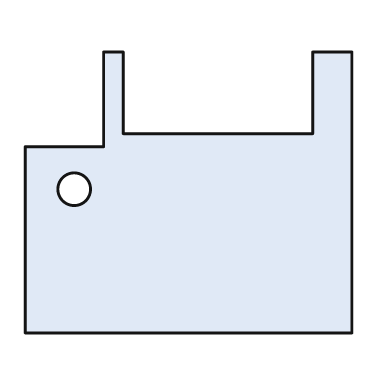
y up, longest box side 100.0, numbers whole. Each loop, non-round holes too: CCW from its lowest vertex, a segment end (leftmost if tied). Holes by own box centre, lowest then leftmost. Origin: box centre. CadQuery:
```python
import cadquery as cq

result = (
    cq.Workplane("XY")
    .moveTo(-50.0, -43.0)
    .lineTo(50.0, -43.0)
    .lineTo(50.0, 43.0)
    .lineTo(38.0, 43.0)
    .lineTo(38.0, 18.0)
    .lineTo(-20.0, 18.0)
    .lineTo(-20.0, 43.0)
    .lineTo(-26.0, 43.0)
    .lineTo(-26.0, 14.0)
    .lineTo(-50.0, 14.0)
    .close()
    .moveTo(-35.0, 1.0)
    .circle(5.0)
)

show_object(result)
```